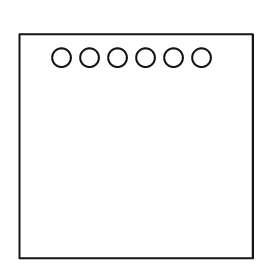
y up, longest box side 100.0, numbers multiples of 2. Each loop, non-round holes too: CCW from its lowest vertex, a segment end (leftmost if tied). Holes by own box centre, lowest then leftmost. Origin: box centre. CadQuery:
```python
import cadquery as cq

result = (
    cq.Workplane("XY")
    .moveTo(-50.0, -48.0)
    .lineTo(50.0, -48.0)
    .lineTo(50.0, 48.0)
    .lineTo(-50.0, 48.0)
    .close()
    .moveTo(-32.0, 38.0)
    .circle(4.0)
    .moveTo(-20.0, 38.0)
    .circle(4.0)
    .moveTo(-8.0, 38.0)
    .circle(4.0)
    .moveTo(4.0, 38.0)
    .circle(4.0)
    .moveTo(16.0, 38.0)
    .circle(4.0)
    .moveTo(28.0, 38.0)
    .circle(4.0)
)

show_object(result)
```